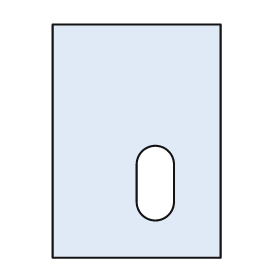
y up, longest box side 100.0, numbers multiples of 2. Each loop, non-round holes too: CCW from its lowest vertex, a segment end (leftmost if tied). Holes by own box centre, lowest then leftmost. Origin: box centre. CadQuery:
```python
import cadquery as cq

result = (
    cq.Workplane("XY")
    .moveTo(-36.0, -50.0)
    .lineTo(36.0, -50.0)
    .lineTo(36.0, 50.0)
    .lineTo(-36.0, 50.0)
    .close()
    .moveTo(0.0, -26.0)
    .threePointArc((8.0, -34.0), (16.0, -26.0))
    .lineTo(16.0, -10.0)
    .threePointArc((8.0, -2.0), (0.0, -10.0))
    .close()
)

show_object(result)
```